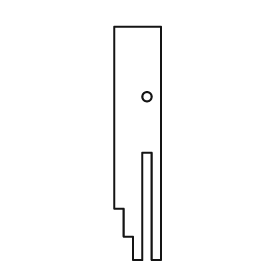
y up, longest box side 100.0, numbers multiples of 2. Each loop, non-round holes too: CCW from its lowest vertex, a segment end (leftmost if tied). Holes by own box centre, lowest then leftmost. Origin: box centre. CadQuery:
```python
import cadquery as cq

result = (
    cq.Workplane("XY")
    .moveTo(-2.0, -50.0)
    .lineTo(2.0, -50.0)
    .lineTo(2.0, -4.0)
    .lineTo(6.0, -4.0)
    .lineTo(6.0, -50.0)
    .lineTo(10.0, -50.0)
    .lineTo(10.0, 50.0)
    .lineTo(-10.0, 50.0)
    .lineTo(-10.0, -28.0)
    .lineTo(-6.0, -28.0)
    .lineTo(-6.0, -40.0)
    .lineTo(-2.0, -40.0)
    .close()
    .moveTo(4.0, 20.0)
    .circle(2.0)
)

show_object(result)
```